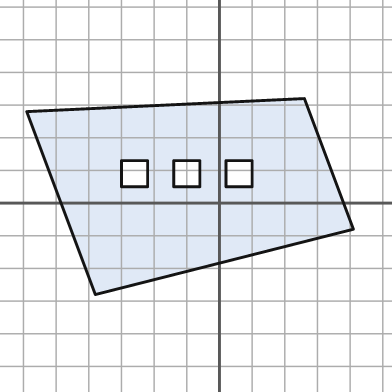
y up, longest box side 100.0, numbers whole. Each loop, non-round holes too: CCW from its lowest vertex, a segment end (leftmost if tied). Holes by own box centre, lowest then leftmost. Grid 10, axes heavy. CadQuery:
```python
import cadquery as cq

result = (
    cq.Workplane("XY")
    .moveTo(-38.0, -28.0)
    .lineTo(41.0, -8.0)
    .lineTo(26.0, 32.0)
    .lineTo(-59.0, 28.0)
    .close()
    .moveTo(-30.0, 5.0)
    .lineTo(-22.0, 5.0)
    .lineTo(-22.0, 13.0)
    .lineTo(-30.0, 13.0)
    .close()
    .moveTo(-14.0, 5.0)
    .lineTo(-6.0, 5.0)
    .lineTo(-6.0, 13.0)
    .lineTo(-14.0, 13.0)
    .close()
    .moveTo(2.0, 5.0)
    .lineTo(10.0, 5.0)
    .lineTo(10.0, 13.0)
    .lineTo(2.0, 13.0)
    .close()
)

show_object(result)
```